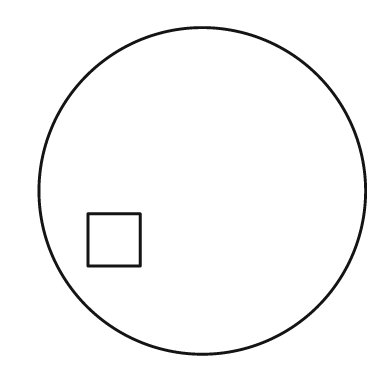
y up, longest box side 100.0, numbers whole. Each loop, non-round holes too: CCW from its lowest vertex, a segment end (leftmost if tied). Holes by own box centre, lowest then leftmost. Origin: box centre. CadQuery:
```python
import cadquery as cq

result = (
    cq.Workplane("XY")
    .moveTo(0.0, 0.0)
    .circle(50.0)
    .moveTo(-35.0, -23.0)
    .lineTo(-19.0, -23.0)
    .lineTo(-19.0, -7.0)
    .lineTo(-35.0, -7.0)
    .close()
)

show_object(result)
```